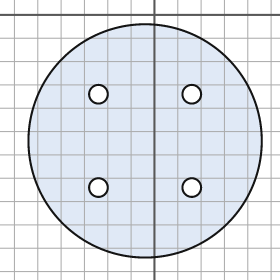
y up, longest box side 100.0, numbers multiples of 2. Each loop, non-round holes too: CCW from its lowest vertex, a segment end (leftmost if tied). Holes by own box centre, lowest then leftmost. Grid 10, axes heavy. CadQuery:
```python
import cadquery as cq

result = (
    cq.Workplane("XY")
    .moveTo(-4.0, -54.0)
    .circle(50.0)
    .moveTo(-24.0, -74.0)
    .circle(4.0)
    .moveTo(16.0, -74.0)
    .circle(4.0)
    .moveTo(-24.0, -34.0)
    .circle(4.0)
    .moveTo(16.0, -34.0)
    .circle(4.0)
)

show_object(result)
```